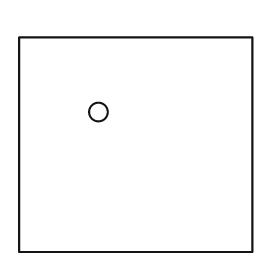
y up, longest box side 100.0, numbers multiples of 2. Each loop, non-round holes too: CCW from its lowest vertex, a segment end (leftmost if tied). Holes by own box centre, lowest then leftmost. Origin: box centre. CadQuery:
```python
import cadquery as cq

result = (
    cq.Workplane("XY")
    .moveTo(-50.0, -46.0)
    .lineTo(50.0, -46.0)
    .lineTo(50.0, 46.0)
    .lineTo(-50.0, 46.0)
    .close()
    .moveTo(-16.0, 14.0)
    .circle(4.0)
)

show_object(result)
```